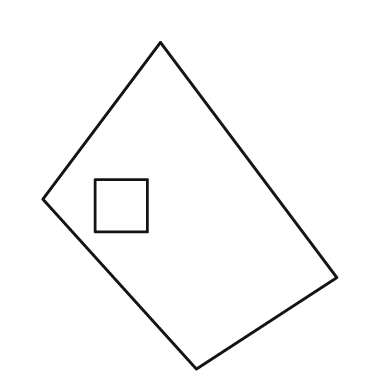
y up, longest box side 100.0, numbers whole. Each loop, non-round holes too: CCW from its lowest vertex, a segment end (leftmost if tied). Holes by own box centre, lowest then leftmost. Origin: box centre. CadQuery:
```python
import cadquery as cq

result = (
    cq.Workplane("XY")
    .moveTo(2.0, -50.0)
    .lineTo(45.0, -22.0)
    .lineTo(-9.0, 50.0)
    .lineTo(-45.0, 2.0)
    .close()
    .moveTo(-29.0, -8.0)
    .lineTo(-13.0, -8.0)
    .lineTo(-13.0, 8.0)
    .lineTo(-29.0, 8.0)
    .close()
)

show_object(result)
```